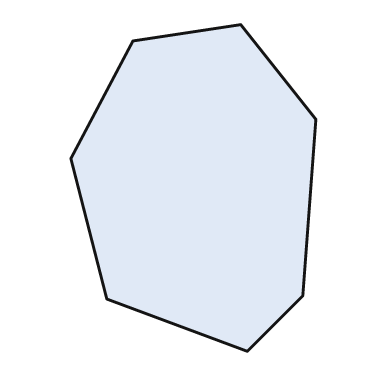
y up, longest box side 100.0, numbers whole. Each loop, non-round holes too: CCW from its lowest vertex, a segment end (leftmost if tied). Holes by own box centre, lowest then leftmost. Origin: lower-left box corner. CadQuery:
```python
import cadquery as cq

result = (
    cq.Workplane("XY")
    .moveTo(54.0, 0.0)
    .lineTo(71.0, 17.0)
    .lineTo(75.0, 71.0)
    .lineTo(52.0, 100.0)
    .lineTo(19.0, 95.0)
    .lineTo(0.0, 59.0)
    .lineTo(11.0, 16.0)
    .close()
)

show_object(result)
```